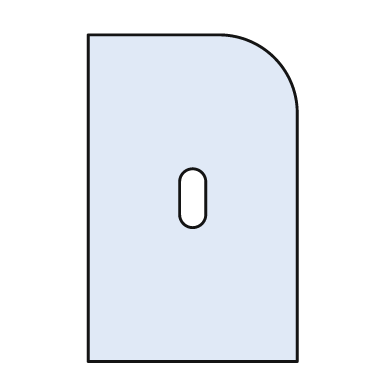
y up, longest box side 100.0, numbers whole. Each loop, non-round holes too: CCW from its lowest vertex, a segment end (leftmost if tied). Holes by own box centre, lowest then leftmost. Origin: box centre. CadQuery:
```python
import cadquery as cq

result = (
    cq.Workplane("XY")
    .moveTo(-32.0, -50.0)
    .lineTo(32.0, -50.0)
    .lineTo(32.0, 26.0)
    .threePointArc((25.0, 43.0), (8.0, 50.0))
    .lineTo(-32.0, 50.0)
    .close()
    .moveTo(-4.0, -5.0)
    .threePointArc((0.0, -9.0), (4.0, -5.0))
    .lineTo(4.0, 5.0)
    .threePointArc((0.0, 9.0), (-4.0, 5.0))
    .close()
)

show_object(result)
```